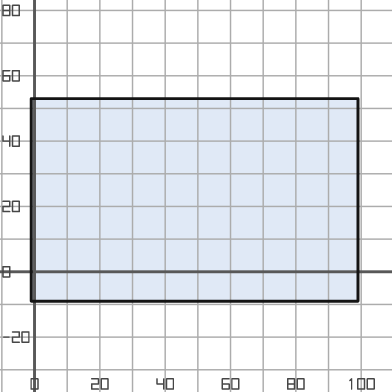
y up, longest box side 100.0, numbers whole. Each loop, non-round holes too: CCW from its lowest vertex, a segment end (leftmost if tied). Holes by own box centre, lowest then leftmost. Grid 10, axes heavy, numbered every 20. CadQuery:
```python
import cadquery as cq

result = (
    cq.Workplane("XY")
    .moveTo(-1.0, -9.0)
    .lineTo(99.0, -9.0)
    .lineTo(99.0, 53.0)
    .lineTo(-1.0, 53.0)
    .close()
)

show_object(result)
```